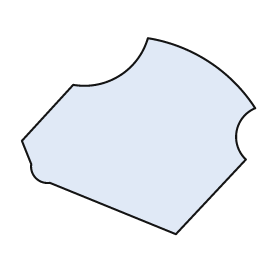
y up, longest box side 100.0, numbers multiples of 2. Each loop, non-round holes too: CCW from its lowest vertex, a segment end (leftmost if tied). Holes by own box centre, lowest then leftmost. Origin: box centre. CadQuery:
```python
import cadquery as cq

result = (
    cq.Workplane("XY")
    .moveTo(16.0, -42.0)
    .lineTo(46.0, -10.0)
    .threePointArc((42.0, 2.0), (50.0, 12.0))
    .threePointArc((30.0, 32.0), (4.0, 42.0))
    .threePointArc((-8.0, 26.0), (-28.0, 22.0))
    .lineTo(-50.0, -2.0)
    .lineTo(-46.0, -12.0)
    .threePointArc((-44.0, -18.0), (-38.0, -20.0))
    .close()
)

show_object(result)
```